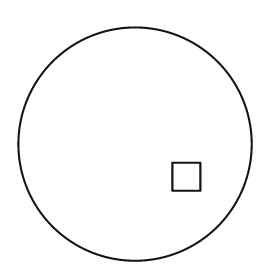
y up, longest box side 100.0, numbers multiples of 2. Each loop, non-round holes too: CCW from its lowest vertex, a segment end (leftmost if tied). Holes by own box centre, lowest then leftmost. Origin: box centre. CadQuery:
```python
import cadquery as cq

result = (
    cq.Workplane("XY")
    .moveTo(0.0, 0.0)
    .circle(50.0)
    .moveTo(16.0, -20.0)
    .lineTo(28.0, -20.0)
    .lineTo(28.0, -8.0)
    .lineTo(16.0, -8.0)
    .close()
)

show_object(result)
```